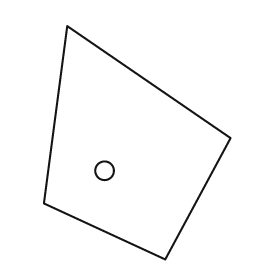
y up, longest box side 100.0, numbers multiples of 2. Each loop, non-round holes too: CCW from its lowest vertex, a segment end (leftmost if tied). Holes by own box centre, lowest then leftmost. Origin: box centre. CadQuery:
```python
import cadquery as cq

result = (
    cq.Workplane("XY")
    .moveTo(12.0, -50.0)
    .lineTo(40.0, 2.0)
    .lineTo(-30.0, 50.0)
    .lineTo(-40.0, -26.0)
    .close()
    .moveTo(-14.0, -12.0)
    .circle(4.0)
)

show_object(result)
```